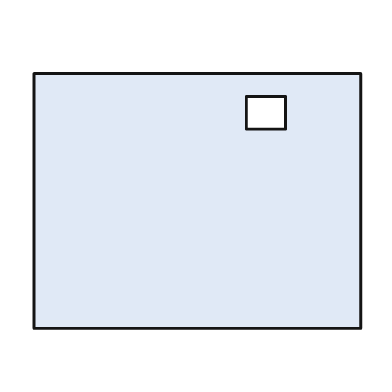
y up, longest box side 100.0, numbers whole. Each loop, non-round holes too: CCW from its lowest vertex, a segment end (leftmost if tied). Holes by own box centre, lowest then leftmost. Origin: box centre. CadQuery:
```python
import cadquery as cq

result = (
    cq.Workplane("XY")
    .moveTo(-50.0, -39.0)
    .lineTo(50.0, -39.0)
    .lineTo(50.0, 39.0)
    .lineTo(-50.0, 39.0)
    .close()
    .moveTo(15.0, 22.0)
    .lineTo(27.0, 22.0)
    .lineTo(27.0, 32.0)
    .lineTo(15.0, 32.0)
    .close()
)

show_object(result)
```